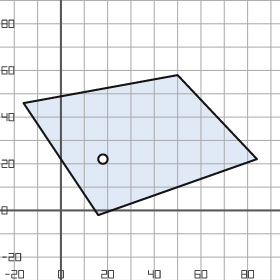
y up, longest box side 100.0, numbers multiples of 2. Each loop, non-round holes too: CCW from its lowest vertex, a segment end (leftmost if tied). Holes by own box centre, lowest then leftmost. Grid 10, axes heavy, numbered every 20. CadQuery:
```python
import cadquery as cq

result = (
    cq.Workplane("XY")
    .moveTo(16.0, -2.0)
    .lineTo(84.0, 22.0)
    .lineTo(50.0, 58.0)
    .lineTo(-16.0, 46.0)
    .close()
    .moveTo(18.0, 22.0)
    .circle(2.0)
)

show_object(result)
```